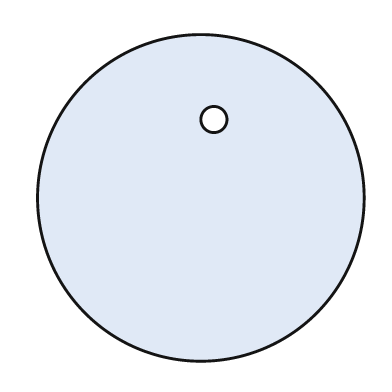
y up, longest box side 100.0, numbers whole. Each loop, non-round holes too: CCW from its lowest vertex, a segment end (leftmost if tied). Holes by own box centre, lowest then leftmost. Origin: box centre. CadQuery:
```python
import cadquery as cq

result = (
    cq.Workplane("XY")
    .moveTo(0.0, 0.0)
    .circle(50.0)
    .moveTo(4.0, 24.0)
    .circle(4.0)
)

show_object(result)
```